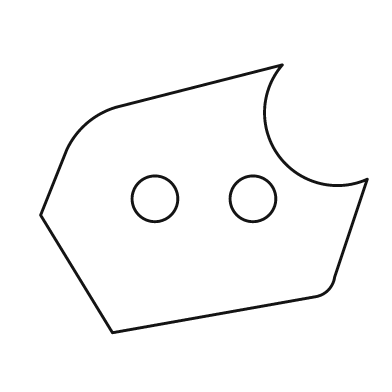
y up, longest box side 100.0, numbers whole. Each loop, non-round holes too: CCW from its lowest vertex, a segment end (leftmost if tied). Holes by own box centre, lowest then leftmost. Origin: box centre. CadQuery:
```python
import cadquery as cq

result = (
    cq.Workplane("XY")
    .moveTo(-28.0, -41.0)
    .lineTo(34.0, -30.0)
    .threePointArc((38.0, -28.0), (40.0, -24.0))
    .lineTo(50.0, 6.0)
    .threePointArc((23.0, 13.0), (24.0, 41.0))
    .lineTo(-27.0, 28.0)
    .threePointArc((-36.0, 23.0), (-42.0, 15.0))
    .lineTo(-50.0, -5.0)
    .close()
    .moveTo(-15.0, 0.0)
    .circle(7.0)
    .moveTo(15.0, 0.0)
    .circle(7.0)
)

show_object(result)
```